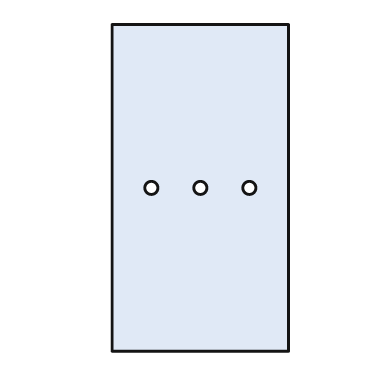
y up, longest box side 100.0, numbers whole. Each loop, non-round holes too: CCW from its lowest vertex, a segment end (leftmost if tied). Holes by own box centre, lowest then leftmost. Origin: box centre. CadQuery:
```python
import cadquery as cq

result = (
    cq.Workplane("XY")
    .moveTo(-27.0, -50.0)
    .lineTo(27.0, -50.0)
    .lineTo(27.0, 50.0)
    .lineTo(-27.0, 50.0)
    .close()
    .moveTo(-15.0, 0.0)
    .circle(2.0)
    .moveTo(0.0, 0.0)
    .circle(2.0)
    .moveTo(15.0, 0.0)
    .circle(2.0)
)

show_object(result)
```